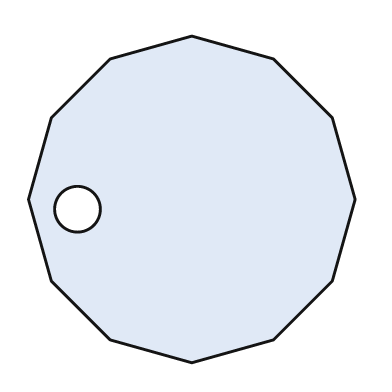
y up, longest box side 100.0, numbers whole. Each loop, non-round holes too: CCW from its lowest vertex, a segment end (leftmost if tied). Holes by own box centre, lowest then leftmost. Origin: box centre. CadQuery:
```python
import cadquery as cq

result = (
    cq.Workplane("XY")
    .moveTo(0.0, -50.0)
    .lineTo(25.0, -43.0)
    .lineTo(43.0, -25.0)
    .lineTo(50.0, 0.0)
    .lineTo(43.0, 25.0)
    .lineTo(25.0, 43.0)
    .lineTo(0.0, 50.0)
    .lineTo(-25.0, 43.0)
    .lineTo(-43.0, 25.0)
    .lineTo(-50.0, 0.0)
    .lineTo(-43.0, -25.0)
    .lineTo(-25.0, -43.0)
    .close()
    .moveTo(-35.0, -3.0)
    .circle(7.0)
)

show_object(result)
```